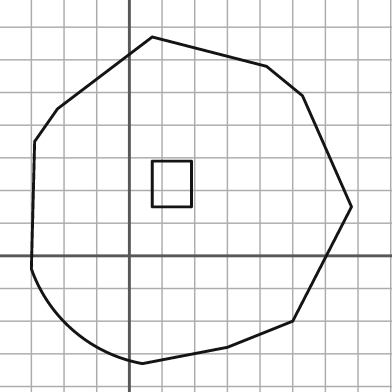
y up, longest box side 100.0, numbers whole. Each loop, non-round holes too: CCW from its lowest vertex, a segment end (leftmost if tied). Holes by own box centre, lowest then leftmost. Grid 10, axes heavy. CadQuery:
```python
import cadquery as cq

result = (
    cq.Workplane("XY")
    .moveTo(4.0, -33.0)
    .lineTo(30.0, -28.0)
    .lineTo(50.0, -20.0)
    .lineTo(68.0, 15.0)
    .lineTo(53.0, 49.0)
    .lineTo(42.0, 58.0)
    .lineTo(7.0, 67.0)
    .lineTo(-22.0, 45.0)
    .lineTo(-29.0, 35.0)
    .lineTo(-30.0, -4.0)
    .threePointArc((-17.0, -23.0), (4.0, -33.0))
    .close()
    .moveTo(7.0, 15.0)
    .lineTo(19.0, 15.0)
    .lineTo(19.0, 29.0)
    .lineTo(7.0, 29.0)
    .close()
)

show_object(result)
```